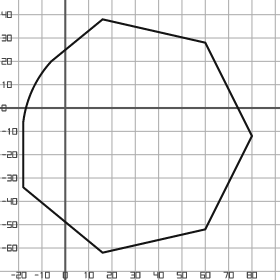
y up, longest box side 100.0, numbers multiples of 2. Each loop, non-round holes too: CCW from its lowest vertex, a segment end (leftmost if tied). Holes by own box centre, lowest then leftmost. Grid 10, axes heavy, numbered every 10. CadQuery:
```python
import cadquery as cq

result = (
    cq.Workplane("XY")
    .moveTo(16.0, -62.0)
    .lineTo(60.0, -52.0)
    .lineTo(80.0, -12.0)
    .lineTo(60.0, 28.0)
    .lineTo(16.0, 38.0)
    .lineTo(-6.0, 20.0)
    .threePointArc((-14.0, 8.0), (-18.0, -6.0))
    .lineTo(-18.0, -34.0)
    .close()
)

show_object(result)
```